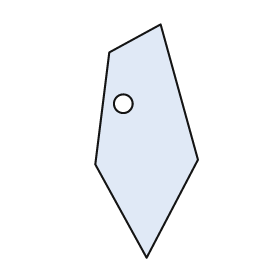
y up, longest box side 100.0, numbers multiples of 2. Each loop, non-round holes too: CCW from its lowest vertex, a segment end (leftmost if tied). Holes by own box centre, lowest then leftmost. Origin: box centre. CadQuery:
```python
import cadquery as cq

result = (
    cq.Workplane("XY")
    .moveTo(0.0, -50.0)
    .lineTo(22.0, -8.0)
    .lineTo(6.0, 50.0)
    .lineTo(-16.0, 38.0)
    .lineTo(-22.0, -10.0)
    .close()
    .moveTo(-10.0, 16.0)
    .circle(4.0)
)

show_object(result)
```